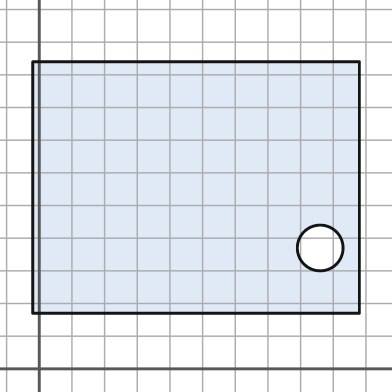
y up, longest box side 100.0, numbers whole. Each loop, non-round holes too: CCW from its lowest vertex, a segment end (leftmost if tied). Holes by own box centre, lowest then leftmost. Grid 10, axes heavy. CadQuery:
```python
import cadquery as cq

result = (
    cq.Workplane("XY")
    .moveTo(-2.0, 17.0)
    .lineTo(98.0, 17.0)
    .lineTo(98.0, 94.0)
    .lineTo(-2.0, 94.0)
    .close()
    .moveTo(86.0, 37.0)
    .circle(7.0)
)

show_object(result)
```